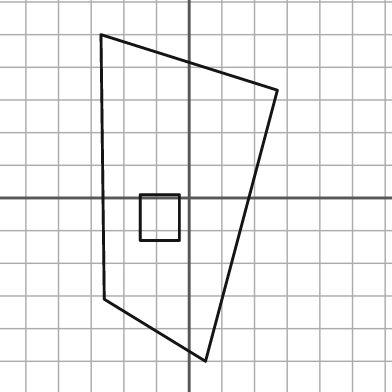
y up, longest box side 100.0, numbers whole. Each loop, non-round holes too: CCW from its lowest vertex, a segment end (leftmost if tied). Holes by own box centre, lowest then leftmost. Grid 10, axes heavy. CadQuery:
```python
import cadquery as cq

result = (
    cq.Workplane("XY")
    .moveTo(5.0, -50.0)
    .lineTo(27.0, 33.0)
    .lineTo(-27.0, 50.0)
    .lineTo(-26.0, -31.0)
    .close()
    .moveTo(-15.0, -13.0)
    .lineTo(-3.0, -13.0)
    .lineTo(-3.0, 1.0)
    .lineTo(-15.0, 1.0)
    .close()
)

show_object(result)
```